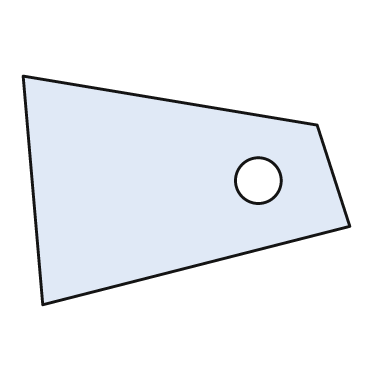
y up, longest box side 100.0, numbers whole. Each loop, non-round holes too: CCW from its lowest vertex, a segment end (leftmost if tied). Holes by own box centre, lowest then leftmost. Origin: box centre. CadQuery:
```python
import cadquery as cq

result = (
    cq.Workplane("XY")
    .moveTo(-44.0, -35.0)
    .lineTo(50.0, -11.0)
    .lineTo(40.0, 20.0)
    .lineTo(-50.0, 35.0)
    .close()
    .moveTo(22.0, 3.0)
    .circle(7.0)
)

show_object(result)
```